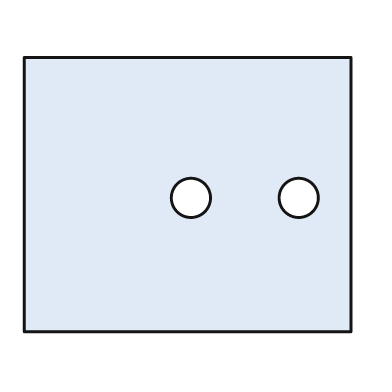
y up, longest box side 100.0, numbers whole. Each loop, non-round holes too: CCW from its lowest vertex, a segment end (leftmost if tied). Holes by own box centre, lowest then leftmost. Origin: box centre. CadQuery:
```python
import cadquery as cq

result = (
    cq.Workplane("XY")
    .moveTo(-50.0, -42.0)
    .lineTo(50.0, -42.0)
    .lineTo(50.0, 42.0)
    .lineTo(-50.0, 42.0)
    .close()
    .moveTo(1.0, -1.0)
    .circle(6.0)
    .moveTo(34.0, -1.0)
    .circle(6.0)
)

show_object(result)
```